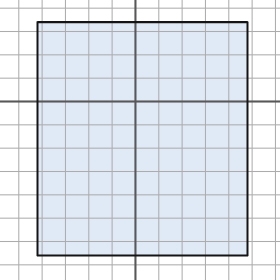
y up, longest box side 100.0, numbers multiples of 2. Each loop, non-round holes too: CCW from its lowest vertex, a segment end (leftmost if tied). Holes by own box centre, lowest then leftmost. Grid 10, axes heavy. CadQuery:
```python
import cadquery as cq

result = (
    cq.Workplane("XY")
    .moveTo(-42.0, -66.0)
    .lineTo(48.0, -66.0)
    .lineTo(48.0, 34.0)
    .lineTo(-42.0, 34.0)
    .close()
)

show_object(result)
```